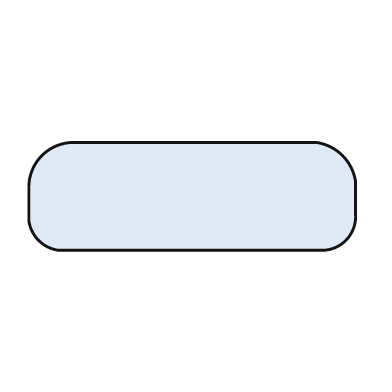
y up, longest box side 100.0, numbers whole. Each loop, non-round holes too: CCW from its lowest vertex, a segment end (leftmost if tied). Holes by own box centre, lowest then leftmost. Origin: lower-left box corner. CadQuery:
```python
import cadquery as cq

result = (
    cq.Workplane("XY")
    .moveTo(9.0, 0.0)
    .lineTo(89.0, 0.0)
    .threePointArc((97.0, 3.0), (100.0, 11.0))
    .lineTo(100.0, 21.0)
    .threePointArc((96.0, 29.0), (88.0, 33.0))
    .lineTo(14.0, 33.0)
    .threePointArc((4.0, 29.0), (0.0, 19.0))
    .lineTo(0.0, 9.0)
    .threePointArc((3.0, 3.0), (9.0, 0.0))
    .close()
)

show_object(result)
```